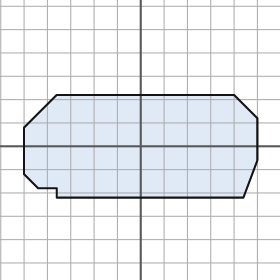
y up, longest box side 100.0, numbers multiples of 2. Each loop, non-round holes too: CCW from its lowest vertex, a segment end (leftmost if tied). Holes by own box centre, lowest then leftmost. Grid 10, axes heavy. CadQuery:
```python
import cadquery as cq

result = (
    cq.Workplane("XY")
    .moveTo(-36.0, -22.0)
    .lineTo(44.0, -22.0)
    .lineTo(50.0, -6.0)
    .lineTo(50.0, 12.0)
    .lineTo(40.0, 22.0)
    .lineTo(-36.0, 22.0)
    .lineTo(-50.0, 8.0)
    .lineTo(-50.0, -12.0)
    .lineTo(-44.0, -18.0)
    .lineTo(-36.0, -18.0)
    .close()
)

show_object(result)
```